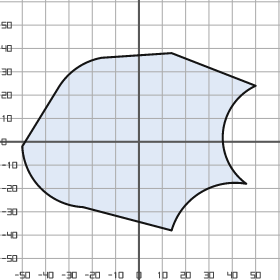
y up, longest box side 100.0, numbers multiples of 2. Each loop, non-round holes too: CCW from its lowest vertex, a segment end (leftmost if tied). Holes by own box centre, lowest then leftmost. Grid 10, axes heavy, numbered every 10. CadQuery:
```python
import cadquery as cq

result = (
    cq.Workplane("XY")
    .moveTo(14.0, -38.0)
    .threePointArc((26.0, -22.0), (46.0, -18.0))
    .threePointArc((36.0, 4.0), (50.0, 24.0))
    .lineTo(14.0, 38.0)
    .lineTo(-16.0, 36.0)
    .threePointArc((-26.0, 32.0), (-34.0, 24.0))
    .lineTo(-50.0, -2.0)
    .threePointArc((-42.0, -20.0), (-24.0, -28.0))
    .close()
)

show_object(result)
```